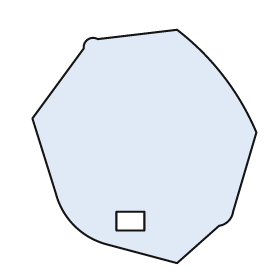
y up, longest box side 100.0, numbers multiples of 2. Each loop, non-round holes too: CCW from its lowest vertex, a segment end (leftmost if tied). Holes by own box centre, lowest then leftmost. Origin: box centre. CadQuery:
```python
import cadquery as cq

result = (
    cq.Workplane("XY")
    .moveTo(14.0, -50.0)
    .lineTo(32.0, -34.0)
    .threePointArc((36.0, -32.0), (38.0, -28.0))
    .lineTo(48.0, 6.0)
    .threePointArc((34.0, 30.0), (14.0, 50.0))
    .lineTo(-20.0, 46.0)
    .threePointArc((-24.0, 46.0), (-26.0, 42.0))
    .lineTo(-48.0, 12.0)
    .lineTo(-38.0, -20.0)
    .threePointArc((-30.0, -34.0), (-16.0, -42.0))
    .close()
    .moveTo(-12.0, -36.0)
    .lineTo(0.0, -36.0)
    .lineTo(0.0, -28.0)
    .lineTo(-12.0, -28.0)
    .close()
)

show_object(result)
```